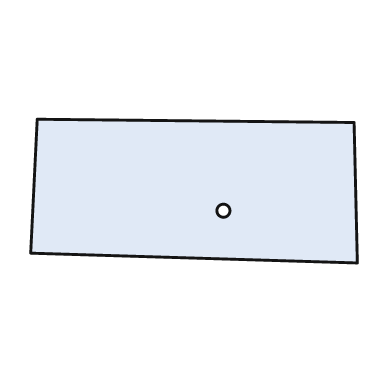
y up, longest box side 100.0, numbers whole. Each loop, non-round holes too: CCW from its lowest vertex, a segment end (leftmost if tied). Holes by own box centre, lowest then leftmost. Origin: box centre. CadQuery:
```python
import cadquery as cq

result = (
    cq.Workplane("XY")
    .moveTo(50.0, -22.0)
    .lineTo(49.0, 21.0)
    .lineTo(-48.0, 22.0)
    .lineTo(-50.0, -19.0)
    .close()
    .moveTo(9.0, -6.0)
    .circle(2.0)
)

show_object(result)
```